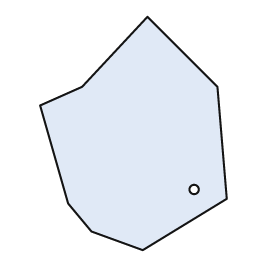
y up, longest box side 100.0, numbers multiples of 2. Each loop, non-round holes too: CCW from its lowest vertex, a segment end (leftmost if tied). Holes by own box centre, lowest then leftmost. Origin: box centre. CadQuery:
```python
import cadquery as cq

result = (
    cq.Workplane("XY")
    .moveTo(4.0, -50.0)
    .lineTo(40.0, -28.0)
    .lineTo(36.0, 20.0)
    .lineTo(6.0, 50.0)
    .lineTo(-22.0, 20.0)
    .lineTo(-40.0, 12.0)
    .lineTo(-28.0, -30.0)
    .lineTo(-18.0, -42.0)
    .close()
    .moveTo(26.0, -24.0)
    .circle(2.0)
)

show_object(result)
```